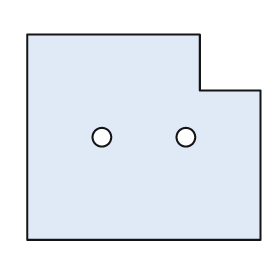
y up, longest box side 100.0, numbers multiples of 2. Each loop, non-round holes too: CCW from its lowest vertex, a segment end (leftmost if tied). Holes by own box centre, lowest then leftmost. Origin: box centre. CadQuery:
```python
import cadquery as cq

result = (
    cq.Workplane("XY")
    .moveTo(-50.0, -44.0)
    .lineTo(50.0, -44.0)
    .lineTo(50.0, 20.0)
    .lineTo(24.0, 20.0)
    .lineTo(24.0, 44.0)
    .lineTo(-50.0, 44.0)
    .close()
    .moveTo(-18.0, 0.0)
    .circle(4.0)
    .moveTo(18.0, 0.0)
    .circle(4.0)
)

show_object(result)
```